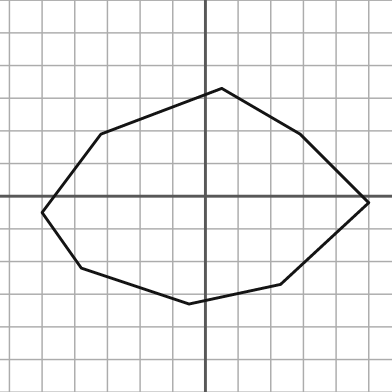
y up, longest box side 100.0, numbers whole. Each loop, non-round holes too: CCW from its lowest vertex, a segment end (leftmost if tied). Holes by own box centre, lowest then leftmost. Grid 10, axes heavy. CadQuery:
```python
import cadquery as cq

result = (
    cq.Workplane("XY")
    .moveTo(-5.0, -33.0)
    .lineTo(23.0, -27.0)
    .lineTo(50.0, -2.0)
    .lineTo(29.0, 19.0)
    .lineTo(5.0, 33.0)
    .lineTo(-32.0, 19.0)
    .lineTo(-50.0, -5.0)
    .lineTo(-38.0, -22.0)
    .close()
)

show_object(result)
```